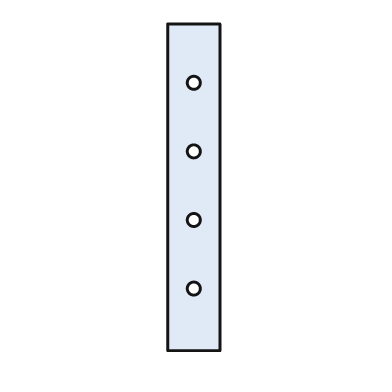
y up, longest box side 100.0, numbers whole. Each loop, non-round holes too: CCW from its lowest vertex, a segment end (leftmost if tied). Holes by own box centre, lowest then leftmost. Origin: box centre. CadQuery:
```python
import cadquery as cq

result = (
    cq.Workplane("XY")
    .moveTo(-8.0, -50.0)
    .lineTo(8.0, -50.0)
    .lineTo(8.0, 50.0)
    .lineTo(-8.0, 50.0)
    .close()
    .moveTo(0.0, -31.0)
    .circle(2.0)
    .moveTo(0.0, -10.0)
    .circle(2.0)
    .moveTo(0.0, 11.0)
    .circle(2.0)
    .moveTo(0.0, 32.0)
    .circle(2.0)
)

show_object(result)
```